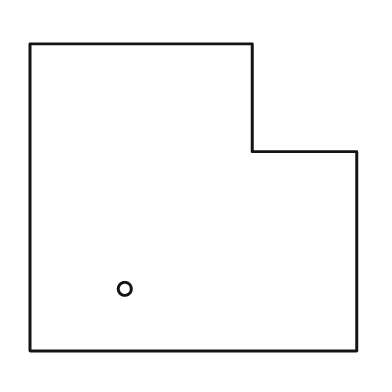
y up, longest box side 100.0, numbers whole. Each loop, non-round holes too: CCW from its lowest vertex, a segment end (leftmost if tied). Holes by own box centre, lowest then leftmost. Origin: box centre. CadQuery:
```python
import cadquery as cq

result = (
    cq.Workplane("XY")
    .moveTo(-50.0, -47.0)
    .lineTo(50.0, -47.0)
    .lineTo(50.0, 14.0)
    .lineTo(18.0, 14.0)
    .lineTo(18.0, 47.0)
    .lineTo(-50.0, 47.0)
    .close()
    .moveTo(-21.0, -28.0)
    .circle(2.0)
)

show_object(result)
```